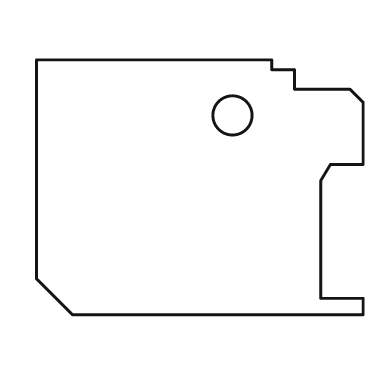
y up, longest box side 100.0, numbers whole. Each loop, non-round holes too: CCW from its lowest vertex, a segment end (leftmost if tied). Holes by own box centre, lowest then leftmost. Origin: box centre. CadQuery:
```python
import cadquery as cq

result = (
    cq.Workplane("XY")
    .moveTo(-39.0, -39.0)
    .lineTo(50.0, -39.0)
    .lineTo(50.0, -34.0)
    .lineTo(37.0, -34.0)
    .lineTo(37.0, 2.0)
    .lineTo(40.0, 7.0)
    .lineTo(50.0, 7.0)
    .lineTo(50.0, 26.0)
    .lineTo(46.0, 30.0)
    .lineTo(29.0, 30.0)
    .lineTo(29.0, 36.0)
    .lineTo(22.0, 36.0)
    .lineTo(22.0, 39.0)
    .lineTo(-50.0, 39.0)
    .lineTo(-50.0, -28.0)
    .close()
    .moveTo(10.0, 22.0)
    .circle(6.0)
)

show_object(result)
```